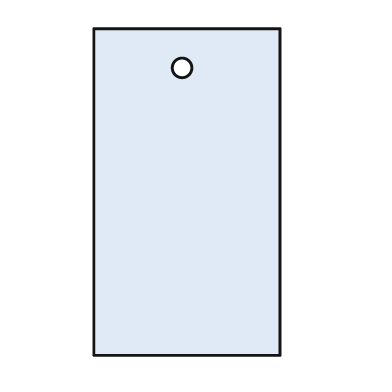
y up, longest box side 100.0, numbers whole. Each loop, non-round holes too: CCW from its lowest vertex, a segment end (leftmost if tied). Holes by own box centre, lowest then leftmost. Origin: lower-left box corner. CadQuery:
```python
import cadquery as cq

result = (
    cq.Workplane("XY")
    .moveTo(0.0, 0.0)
    .lineTo(57.0, 0.0)
    .lineTo(57.0, 100.0)
    .lineTo(0.0, 100.0)
    .close()
    .moveTo(27.0, 88.0)
    .circle(3.0)
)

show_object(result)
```